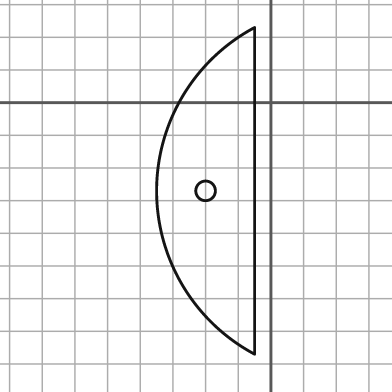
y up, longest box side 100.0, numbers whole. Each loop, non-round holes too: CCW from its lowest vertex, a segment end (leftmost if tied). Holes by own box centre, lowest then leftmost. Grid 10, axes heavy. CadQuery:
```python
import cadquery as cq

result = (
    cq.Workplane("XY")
    .moveTo(-5.0, -77.0)
    .lineTo(-5.0, 23.0)
    .threePointArc((-35.0, -27.0), (-5.0, -77.0))
    .close()
    .moveTo(-20.0, -27.0)
    .circle(3.0)
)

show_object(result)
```